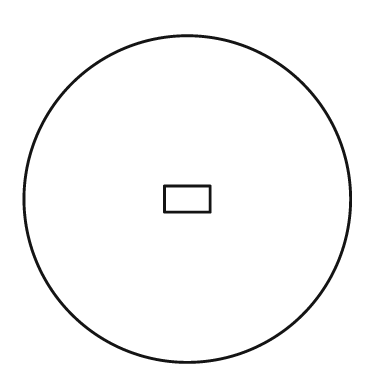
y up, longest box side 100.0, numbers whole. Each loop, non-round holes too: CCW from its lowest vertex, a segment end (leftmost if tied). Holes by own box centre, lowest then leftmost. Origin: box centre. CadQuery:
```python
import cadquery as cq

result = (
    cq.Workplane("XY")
    .moveTo(0.0, 0.0)
    .circle(50.0)
    .moveTo(-7.0, -4.0)
    .lineTo(7.0, -4.0)
    .lineTo(7.0, 4.0)
    .lineTo(-7.0, 4.0)
    .close()
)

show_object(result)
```